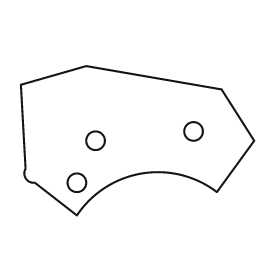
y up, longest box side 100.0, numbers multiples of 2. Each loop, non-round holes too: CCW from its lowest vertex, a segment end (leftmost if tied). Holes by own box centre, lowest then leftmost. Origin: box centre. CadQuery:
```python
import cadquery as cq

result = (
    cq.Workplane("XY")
    .moveTo(-26.0, -32.0)
    .threePointArc((2.0, -14.0), (34.0, -22.0))
    .lineTo(50.0, 0.0)
    .lineTo(36.0, 22.0)
    .lineTo(-22.0, 32.0)
    .lineTo(-50.0, 24.0)
    .lineTo(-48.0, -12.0)
    .threePointArc((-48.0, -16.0), (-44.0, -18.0))
    .close()
    .moveTo(-26.0, -18.0)
    .circle(4.0)
    .moveTo(-18.0, 0.0)
    .circle(4.0)
    .moveTo(24.0, 4.0)
    .circle(4.0)
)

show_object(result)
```